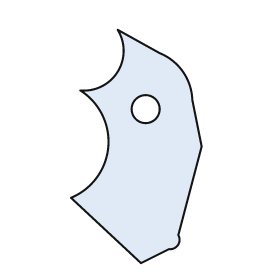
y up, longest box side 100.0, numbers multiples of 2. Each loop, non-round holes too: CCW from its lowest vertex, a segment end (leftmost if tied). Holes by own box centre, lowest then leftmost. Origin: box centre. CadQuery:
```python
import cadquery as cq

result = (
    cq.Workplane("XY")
    .moveTo(2.0, -50.0)
    .lineTo(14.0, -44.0)
    .threePointArc((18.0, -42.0), (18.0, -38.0))
    .lineTo(28.0, 0.0)
    .lineTo(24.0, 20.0)
    .threePointArc((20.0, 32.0), (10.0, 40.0))
    .lineTo(-8.0, 50.0)
    .threePointArc((-8.0, 32.0), (-24.0, 24.0))
    .threePointArc((-12.0, 0.0), (-28.0, -22.0))
    .close()
    .moveTo(4.0, 16.0)
    .circle(6.0)
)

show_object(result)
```